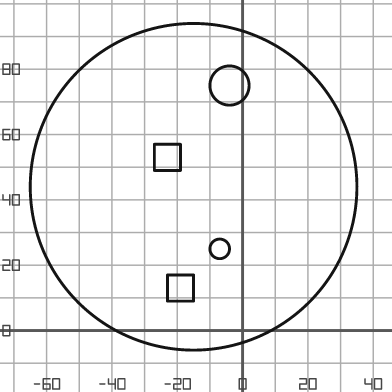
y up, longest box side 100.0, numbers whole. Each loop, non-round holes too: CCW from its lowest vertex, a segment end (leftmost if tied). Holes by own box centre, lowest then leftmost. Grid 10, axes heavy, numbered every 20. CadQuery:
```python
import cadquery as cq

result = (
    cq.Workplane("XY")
    .moveTo(-15.0, 44.0)
    .circle(50.0)
    .moveTo(-23.0, 9.0)
    .lineTo(-15.0, 9.0)
    .lineTo(-15.0, 17.0)
    .lineTo(-23.0, 17.0)
    .close()
    .moveTo(-7.0, 25.0)
    .circle(3.0)
    .moveTo(-27.0, 49.0)
    .lineTo(-19.0, 49.0)
    .lineTo(-19.0, 57.0)
    .lineTo(-27.0, 57.0)
    .close()
    .moveTo(-4.0, 75.0)
    .circle(6.0)
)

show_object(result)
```